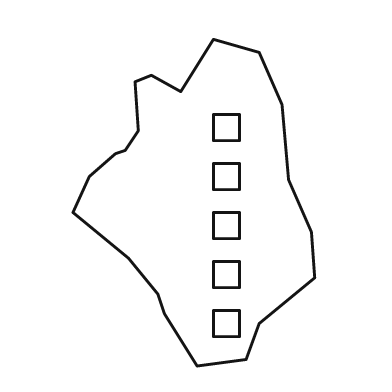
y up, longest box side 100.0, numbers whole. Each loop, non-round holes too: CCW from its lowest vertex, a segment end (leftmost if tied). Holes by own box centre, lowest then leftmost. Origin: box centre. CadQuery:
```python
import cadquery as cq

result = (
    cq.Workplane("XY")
    .moveTo(1.0, -50.0)
    .lineTo(16.0, -48.0)
    .lineTo(20.0, -37.0)
    .lineTo(37.0, -23.0)
    .lineTo(36.0, -9.0)
    .lineTo(29.0, 7.0)
    .lineTo(27.0, 30.0)
    .lineTo(20.0, 46.0)
    .lineTo(6.0, 50.0)
    .lineTo(-4.0, 34.0)
    .lineTo(-13.0, 39.0)
    .lineTo(-18.0, 37.0)
    .lineTo(-17.0, 22.0)
    .lineTo(-21.0, 16.0)
    .lineTo(-24.0, 15.0)
    .lineTo(-32.0, 8.0)
    .lineTo(-37.0, -3.0)
    .lineTo(-20.0, -17.0)
    .lineTo(-11.0, -28.0)
    .lineTo(-9.0, -34.0)
    .close()
    .moveTo(6.0, -41.0)
    .lineTo(14.0, -41.0)
    .lineTo(14.0, -33.0)
    .lineTo(6.0, -33.0)
    .close()
    .moveTo(6.0, -26.0)
    .lineTo(14.0, -26.0)
    .lineTo(14.0, -18.0)
    .lineTo(6.0, -18.0)
    .close()
    .moveTo(6.0, -11.0)
    .lineTo(14.0, -11.0)
    .lineTo(14.0, -3.0)
    .lineTo(6.0, -3.0)
    .close()
    .moveTo(6.0, 4.0)
    .lineTo(14.0, 4.0)
    .lineTo(14.0, 12.0)
    .lineTo(6.0, 12.0)
    .close()
    .moveTo(6.0, 19.0)
    .lineTo(14.0, 19.0)
    .lineTo(14.0, 27.0)
    .lineTo(6.0, 27.0)
    .close()
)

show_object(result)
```